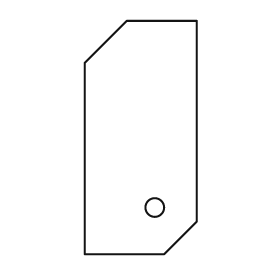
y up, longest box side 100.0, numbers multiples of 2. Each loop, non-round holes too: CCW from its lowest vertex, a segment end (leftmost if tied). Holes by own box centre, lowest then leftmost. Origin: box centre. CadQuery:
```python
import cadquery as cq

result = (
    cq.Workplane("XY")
    .moveTo(-24.0, -50.0)
    .lineTo(10.0, -50.0)
    .lineTo(24.0, -36.0)
    .lineTo(24.0, 50.0)
    .lineTo(-6.0, 50.0)
    .lineTo(-24.0, 32.0)
    .close()
    .moveTo(6.0, -30.0)
    .circle(4.0)
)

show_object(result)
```